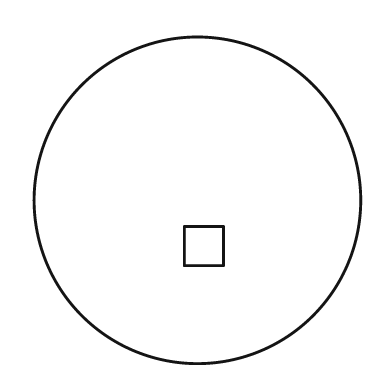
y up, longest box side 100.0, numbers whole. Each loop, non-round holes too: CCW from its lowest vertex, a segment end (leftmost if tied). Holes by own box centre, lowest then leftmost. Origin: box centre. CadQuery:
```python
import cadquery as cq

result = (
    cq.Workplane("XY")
    .moveTo(0.0, 0.0)
    .circle(50.0)
    .moveTo(-4.0, -20.0)
    .lineTo(8.0, -20.0)
    .lineTo(8.0, -8.0)
    .lineTo(-4.0, -8.0)
    .close()
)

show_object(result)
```